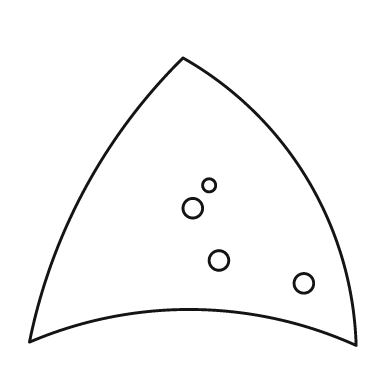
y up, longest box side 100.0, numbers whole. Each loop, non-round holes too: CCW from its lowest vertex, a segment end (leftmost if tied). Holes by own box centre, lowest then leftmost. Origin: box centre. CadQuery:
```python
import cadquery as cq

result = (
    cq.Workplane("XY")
    .moveTo(50.0, -44.0)
    .threePointArc((35.0, 7.0), (-3.0, 44.0))
    .threePointArc((-33.0, 4.0), (-50.0, -43.0))
    .threePointArc((0.0, -33.0), (50.0, -44.0))
    .close()
    .moveTo(34.0, -25.0)
    .circle(3.0)
    .moveTo(8.0, -18.0)
    .circle(3.0)
    .moveTo(0.0, -2.0)
    .circle(3.0)
    .moveTo(5.0, 5.0)
    .circle(2.0)
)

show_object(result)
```